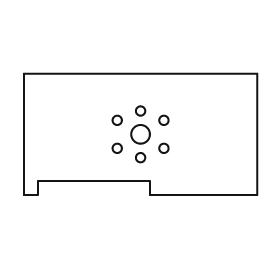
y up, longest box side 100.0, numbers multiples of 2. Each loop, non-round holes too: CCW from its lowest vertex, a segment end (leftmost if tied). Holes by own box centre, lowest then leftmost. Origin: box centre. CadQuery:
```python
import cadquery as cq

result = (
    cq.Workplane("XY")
    .moveTo(-50.0, -26.0)
    .lineTo(-44.0, -26.0)
    .lineTo(-44.0, -20.0)
    .lineTo(4.0, -20.0)
    .lineTo(4.0, -26.0)
    .lineTo(50.0, -26.0)
    .lineTo(50.0, 26.0)
    .lineTo(-50.0, 26.0)
    .close()
    .moveTo(0.0, -10.0)
    .circle(2.0)
    .moveTo(-10.0, -6.0)
    .circle(2.0)
    .moveTo(10.0, -6.0)
    .circle(2.0)
    .moveTo(0.0, 0.0)
    .circle(4.0)
    .moveTo(-10.0, 6.0)
    .circle(2.0)
    .moveTo(10.0, 6.0)
    .circle(2.0)
    .moveTo(0.0, 10.0)
    .circle(2.0)
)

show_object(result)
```